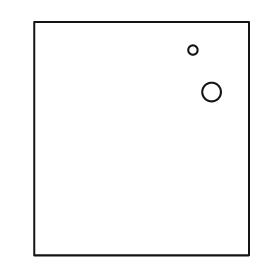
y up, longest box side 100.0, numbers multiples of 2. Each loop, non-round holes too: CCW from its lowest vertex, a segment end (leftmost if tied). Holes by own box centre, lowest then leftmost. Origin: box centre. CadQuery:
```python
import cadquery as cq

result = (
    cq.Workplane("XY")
    .moveTo(-46.0, -50.0)
    .lineTo(46.0, -50.0)
    .lineTo(46.0, 50.0)
    .lineTo(-46.0, 50.0)
    .close()
    .moveTo(30.0, 20.0)
    .circle(4.0)
    .moveTo(22.0, 38.0)
    .circle(2.0)
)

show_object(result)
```